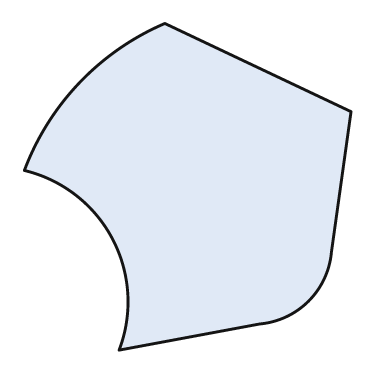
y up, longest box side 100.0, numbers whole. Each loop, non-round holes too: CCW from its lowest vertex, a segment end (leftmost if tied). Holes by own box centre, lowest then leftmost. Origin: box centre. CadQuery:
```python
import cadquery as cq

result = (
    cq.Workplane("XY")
    .moveTo(-21.0, -50.0)
    .lineTo(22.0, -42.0)
    .threePointArc((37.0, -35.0), (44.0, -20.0))
    .lineTo(50.0, 23.0)
    .lineTo(-7.0, 50.0)
    .threePointArc((-33.0, 32.0), (-50.0, 5.0))
    .threePointArc((-23.0, -16.0), (-21.0, -50.0))
    .close()
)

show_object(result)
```